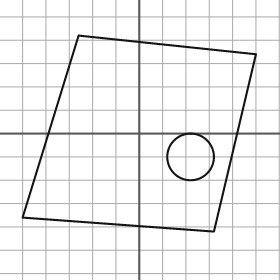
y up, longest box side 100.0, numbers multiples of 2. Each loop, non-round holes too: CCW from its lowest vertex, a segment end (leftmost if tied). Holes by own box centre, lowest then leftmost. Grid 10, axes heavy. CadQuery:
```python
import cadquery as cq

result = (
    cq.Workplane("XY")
    .moveTo(32.0, -42.0)
    .lineTo(50.0, 34.0)
    .lineTo(-26.0, 42.0)
    .lineTo(-50.0, -36.0)
    .close()
    .moveTo(22.0, -10.0)
    .circle(10.0)
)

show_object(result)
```